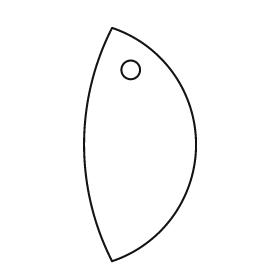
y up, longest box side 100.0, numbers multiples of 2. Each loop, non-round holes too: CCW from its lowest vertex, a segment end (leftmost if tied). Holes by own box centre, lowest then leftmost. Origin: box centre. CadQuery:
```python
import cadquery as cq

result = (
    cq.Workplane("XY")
    .moveTo(-12.0, -50.0)
    .threePointArc((24.0, 0.0), (-12.0, 50.0))
    .threePointArc((-24.0, 0.0), (-12.0, -50.0))
    .close()
    .moveTo(-4.0, 32.0)
    .circle(4.0)
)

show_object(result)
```